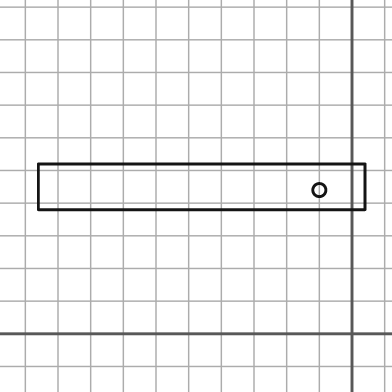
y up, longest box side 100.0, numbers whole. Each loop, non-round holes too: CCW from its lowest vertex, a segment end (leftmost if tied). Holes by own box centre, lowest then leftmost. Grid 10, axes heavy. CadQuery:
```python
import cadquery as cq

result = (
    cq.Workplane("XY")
    .moveTo(-96.0, 38.0)
    .lineTo(4.0, 38.0)
    .lineTo(4.0, 52.0)
    .lineTo(-96.0, 52.0)
    .close()
    .moveTo(-10.0, 44.0)
    .circle(2.0)
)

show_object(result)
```